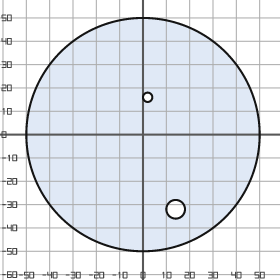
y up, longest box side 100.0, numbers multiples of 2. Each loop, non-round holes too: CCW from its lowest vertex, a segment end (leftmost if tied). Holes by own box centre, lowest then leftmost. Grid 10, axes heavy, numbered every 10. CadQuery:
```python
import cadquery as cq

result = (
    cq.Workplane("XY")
    .moveTo(0.0, 0.0)
    .circle(50.0)
    .moveTo(14.0, -32.0)
    .circle(4.0)
    .moveTo(2.0, 16.0)
    .circle(2.0)
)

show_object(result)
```